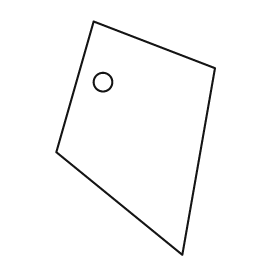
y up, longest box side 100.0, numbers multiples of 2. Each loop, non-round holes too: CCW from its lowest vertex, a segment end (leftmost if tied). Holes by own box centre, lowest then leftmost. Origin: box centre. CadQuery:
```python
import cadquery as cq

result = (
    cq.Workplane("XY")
    .moveTo(20.0, -50.0)
    .lineTo(34.0, 30.0)
    .lineTo(-18.0, 50.0)
    .lineTo(-34.0, -6.0)
    .close()
    .moveTo(-14.0, 24.0)
    .circle(4.0)
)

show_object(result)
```